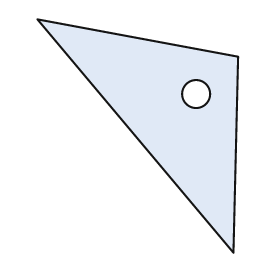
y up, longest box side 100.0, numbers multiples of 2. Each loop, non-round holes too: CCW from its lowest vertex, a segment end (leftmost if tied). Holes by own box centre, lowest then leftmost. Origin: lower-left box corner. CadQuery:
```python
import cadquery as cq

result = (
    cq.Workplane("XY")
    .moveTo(84.0, 0.0)
    .lineTo(86.0, 84.0)
    .lineTo(0.0, 100.0)
    .close()
    .moveTo(68.0, 68.0)
    .circle(6.0)
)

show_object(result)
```